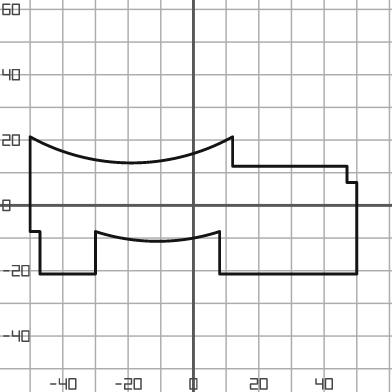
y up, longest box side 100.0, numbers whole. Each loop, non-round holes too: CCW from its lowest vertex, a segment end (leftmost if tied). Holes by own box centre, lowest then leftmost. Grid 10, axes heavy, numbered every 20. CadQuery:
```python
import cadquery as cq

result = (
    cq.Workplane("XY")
    .moveTo(-47.0, -21.0)
    .lineTo(-30.0, -21.0)
    .lineTo(-30.0, -8.0)
    .threePointArc((-11.0, -11.0), (8.0, -8.0))
    .lineTo(8.0, -21.0)
    .lineTo(50.0, -21.0)
    .lineTo(50.0, 7.0)
    .lineTo(47.0, 7.0)
    .lineTo(47.0, 12.0)
    .lineTo(12.0, 12.0)
    .lineTo(12.0, 21.0)
    .threePointArc((-19.0, 13.0), (-50.0, 21.0))
    .lineTo(-50.0, -8.0)
    .lineTo(-47.0, -8.0)
    .close()
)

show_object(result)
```